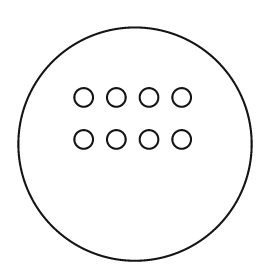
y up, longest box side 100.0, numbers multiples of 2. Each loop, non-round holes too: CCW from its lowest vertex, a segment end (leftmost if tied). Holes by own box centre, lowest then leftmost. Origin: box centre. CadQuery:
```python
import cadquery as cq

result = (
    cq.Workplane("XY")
    .moveTo(0.0, 0.0)
    .circle(50.0)
    .moveTo(-22.0, 2.0)
    .circle(4.0)
    .moveTo(-8.0, 2.0)
    .circle(4.0)
    .moveTo(6.0, 2.0)
    .circle(4.0)
    .moveTo(20.0, 2.0)
    .circle(4.0)
    .moveTo(-22.0, 20.0)
    .circle(4.0)
    .moveTo(-8.0, 20.0)
    .circle(4.0)
    .moveTo(6.0, 20.0)
    .circle(4.0)
    .moveTo(20.0, 20.0)
    .circle(4.0)
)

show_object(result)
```